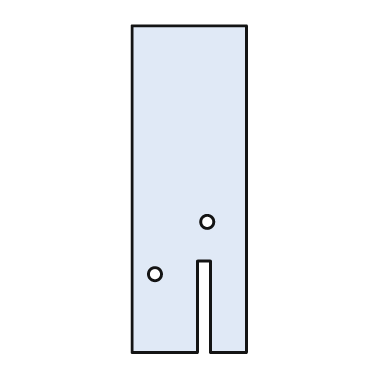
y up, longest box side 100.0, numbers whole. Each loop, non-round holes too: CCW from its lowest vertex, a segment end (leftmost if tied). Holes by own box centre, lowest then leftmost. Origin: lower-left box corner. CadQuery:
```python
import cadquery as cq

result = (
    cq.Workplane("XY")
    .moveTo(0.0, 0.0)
    .lineTo(20.0, 0.0)
    .lineTo(20.0, 28.0)
    .lineTo(24.0, 28.0)
    .lineTo(24.0, 0.0)
    .lineTo(35.0, 0.0)
    .lineTo(35.0, 100.0)
    .lineTo(0.0, 100.0)
    .close()
    .moveTo(7.0, 24.0)
    .circle(2.0)
    .moveTo(23.0, 40.0)
    .circle(2.0)
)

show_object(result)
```